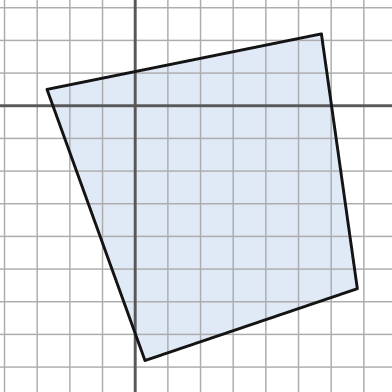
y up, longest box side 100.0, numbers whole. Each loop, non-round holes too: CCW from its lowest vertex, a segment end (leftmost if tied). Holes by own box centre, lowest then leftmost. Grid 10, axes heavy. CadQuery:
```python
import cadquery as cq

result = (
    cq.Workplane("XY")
    .moveTo(3.0, -78.0)
    .lineTo(68.0, -56.0)
    .lineTo(57.0, 22.0)
    .lineTo(-27.0, 5.0)
    .close()
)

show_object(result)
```